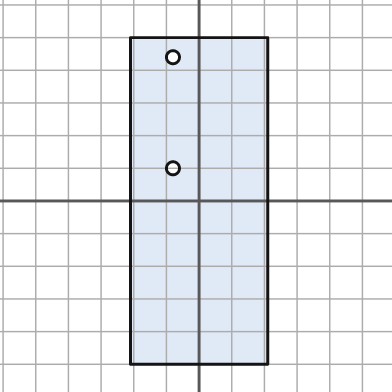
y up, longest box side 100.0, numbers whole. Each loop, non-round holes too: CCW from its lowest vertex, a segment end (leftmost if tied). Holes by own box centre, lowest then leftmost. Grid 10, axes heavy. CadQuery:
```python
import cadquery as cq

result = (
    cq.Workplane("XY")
    .moveTo(-21.0, -50.0)
    .lineTo(21.0, -50.0)
    .lineTo(21.0, 50.0)
    .lineTo(-21.0, 50.0)
    .close()
    .moveTo(-8.0, 10.0)
    .circle(2.0)
    .moveTo(-8.0, 44.0)
    .circle(2.0)
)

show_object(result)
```